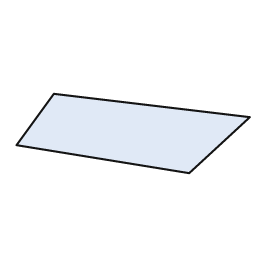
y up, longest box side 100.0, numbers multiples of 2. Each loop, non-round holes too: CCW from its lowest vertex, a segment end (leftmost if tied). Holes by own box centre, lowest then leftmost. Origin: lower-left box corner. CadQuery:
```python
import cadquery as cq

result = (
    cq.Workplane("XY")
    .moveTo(74.0, 0.0)
    .lineTo(100.0, 24.0)
    .lineTo(16.0, 34.0)
    .lineTo(0.0, 12.0)
    .close()
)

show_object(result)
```